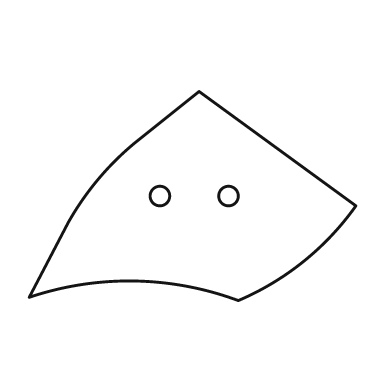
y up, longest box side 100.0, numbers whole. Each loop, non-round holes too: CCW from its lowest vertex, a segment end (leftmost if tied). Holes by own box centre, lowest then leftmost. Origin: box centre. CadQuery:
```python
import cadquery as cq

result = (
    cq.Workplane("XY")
    .moveTo(14.0, -32.0)
    .threePointArc((34.0, -20.0), (50.0, -3.0))
    .lineTo(2.0, 32.0)
    .lineTo(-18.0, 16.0)
    .threePointArc((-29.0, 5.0), (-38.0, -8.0))
    .lineTo(-50.0, -31.0)
    .threePointArc((-18.0, -26.0), (14.0, -32.0))
    .close()
    .moveTo(-10.0, 0.0)
    .circle(3.0)
    .moveTo(11.0, 0.0)
    .circle(3.0)
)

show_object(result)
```